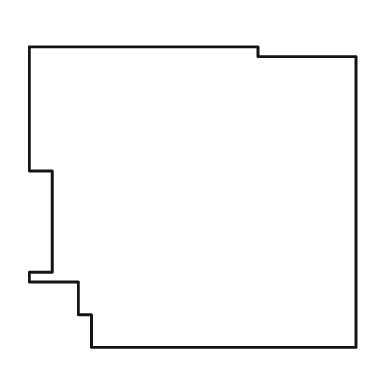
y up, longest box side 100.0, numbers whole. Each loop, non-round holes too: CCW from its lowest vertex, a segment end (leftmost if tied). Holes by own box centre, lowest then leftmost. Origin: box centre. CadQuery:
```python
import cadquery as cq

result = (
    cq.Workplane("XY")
    .moveTo(-31.0, -46.0)
    .lineTo(50.0, -46.0)
    .lineTo(50.0, 43.0)
    .lineTo(20.0, 43.0)
    .lineTo(20.0, 46.0)
    .lineTo(-50.0, 46.0)
    .lineTo(-50.0, 8.0)
    .lineTo(-43.0, 8.0)
    .lineTo(-43.0, -23.0)
    .lineTo(-50.0, -23.0)
    .lineTo(-50.0, -26.0)
    .lineTo(-35.0, -26.0)
    .lineTo(-35.0, -36.0)
    .lineTo(-31.0, -36.0)
    .close()
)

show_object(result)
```